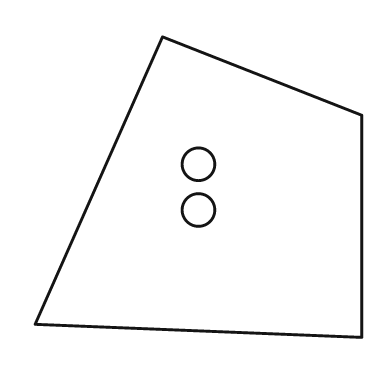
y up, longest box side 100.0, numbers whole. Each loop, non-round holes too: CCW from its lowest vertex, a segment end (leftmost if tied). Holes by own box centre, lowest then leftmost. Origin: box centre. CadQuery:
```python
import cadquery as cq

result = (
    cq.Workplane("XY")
    .moveTo(50.0, -46.0)
    .lineTo(50.0, 22.0)
    .lineTo(-11.0, 46.0)
    .lineTo(-50.0, -42.0)
    .close()
    .moveTo(0.0, -7.0)
    .circle(5.0)
    .moveTo(0.0, 7.0)
    .circle(5.0)
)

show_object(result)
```